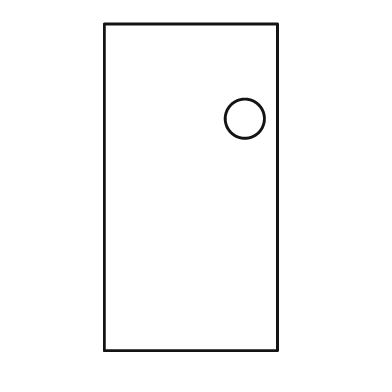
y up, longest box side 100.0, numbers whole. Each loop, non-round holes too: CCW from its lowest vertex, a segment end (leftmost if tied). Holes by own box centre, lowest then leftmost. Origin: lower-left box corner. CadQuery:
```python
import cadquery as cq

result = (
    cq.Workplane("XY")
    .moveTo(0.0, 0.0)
    .lineTo(53.0, 0.0)
    .lineTo(53.0, 100.0)
    .lineTo(0.0, 100.0)
    .close()
    .moveTo(43.0, 71.0)
    .circle(6.0)
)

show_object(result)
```